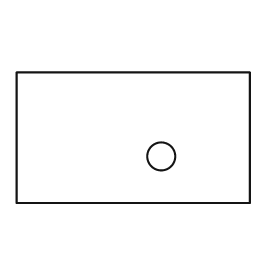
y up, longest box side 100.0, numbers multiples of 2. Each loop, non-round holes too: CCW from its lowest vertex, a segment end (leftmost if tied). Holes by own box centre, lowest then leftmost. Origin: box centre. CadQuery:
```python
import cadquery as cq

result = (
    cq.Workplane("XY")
    .moveTo(-50.0, -28.0)
    .lineTo(50.0, -28.0)
    .lineTo(50.0, 28.0)
    .lineTo(-50.0, 28.0)
    .close()
    .moveTo(12.0, -8.0)
    .circle(6.0)
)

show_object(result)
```